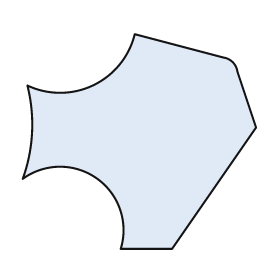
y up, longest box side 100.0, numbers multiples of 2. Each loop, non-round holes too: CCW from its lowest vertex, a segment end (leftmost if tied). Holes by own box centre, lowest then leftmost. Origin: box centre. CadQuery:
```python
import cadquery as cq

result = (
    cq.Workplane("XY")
    .moveTo(-8.0, -46.0)
    .lineTo(14.0, -46.0)
    .lineTo(50.0, 6.0)
    .lineTo(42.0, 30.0)
    .threePointArc((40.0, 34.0), (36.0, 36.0))
    .lineTo(-2.0, 46.0)
    .threePointArc((-20.0, 24.0), (-48.0, 24.0))
    .threePointArc((-46.0, 4.0), (-50.0, -16.0))
    .threePointArc((-18.0, -16.0), (-8.0, -46.0))
    .close()
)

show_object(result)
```